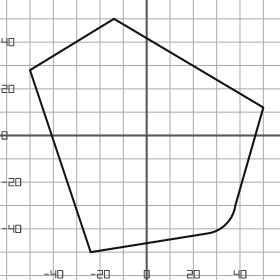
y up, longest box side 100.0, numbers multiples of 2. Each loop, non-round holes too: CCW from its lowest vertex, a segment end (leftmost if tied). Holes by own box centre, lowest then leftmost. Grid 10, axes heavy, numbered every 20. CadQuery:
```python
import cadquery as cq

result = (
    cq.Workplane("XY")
    .moveTo(-24.0, -50.0)
    .lineTo(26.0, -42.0)
    .threePointArc((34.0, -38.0), (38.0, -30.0))
    .lineTo(50.0, 12.0)
    .lineTo(-14.0, 50.0)
    .lineTo(-50.0, 28.0)
    .close()
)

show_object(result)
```